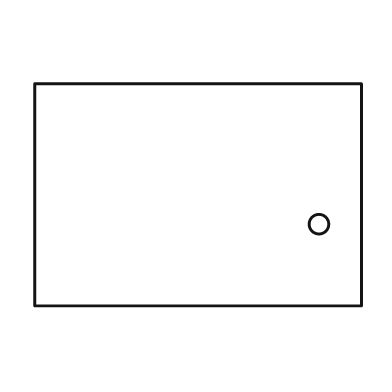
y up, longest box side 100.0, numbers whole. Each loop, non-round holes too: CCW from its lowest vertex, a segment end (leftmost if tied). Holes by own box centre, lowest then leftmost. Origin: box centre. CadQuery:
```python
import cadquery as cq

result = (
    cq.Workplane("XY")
    .moveTo(-50.0, -34.0)
    .lineTo(50.0, -34.0)
    .lineTo(50.0, 34.0)
    .lineTo(-50.0, 34.0)
    .close()
    .moveTo(37.0, -9.0)
    .circle(3.0)
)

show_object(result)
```